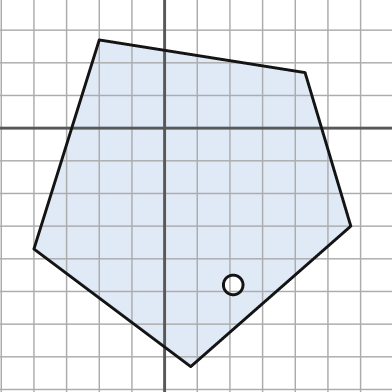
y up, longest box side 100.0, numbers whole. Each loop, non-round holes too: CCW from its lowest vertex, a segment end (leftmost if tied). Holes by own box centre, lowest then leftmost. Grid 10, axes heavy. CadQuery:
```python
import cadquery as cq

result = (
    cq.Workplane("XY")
    .moveTo(8.0, -73.0)
    .lineTo(57.0, -30.0)
    .lineTo(43.0, 17.0)
    .lineTo(-20.0, 27.0)
    .lineTo(-40.0, -37.0)
    .close()
    .moveTo(21.0, -48.0)
    .circle(3.0)
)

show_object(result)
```